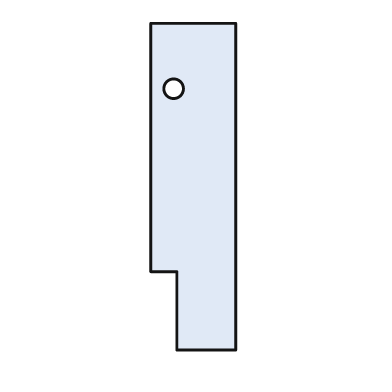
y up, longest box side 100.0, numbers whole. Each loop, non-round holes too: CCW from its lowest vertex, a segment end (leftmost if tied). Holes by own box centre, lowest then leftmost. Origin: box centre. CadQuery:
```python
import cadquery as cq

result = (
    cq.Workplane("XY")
    .moveTo(-5.0, -50.0)
    .lineTo(13.0, -50.0)
    .lineTo(13.0, 50.0)
    .lineTo(-13.0, 50.0)
    .lineTo(-13.0, -26.0)
    .lineTo(-5.0, -26.0)
    .close()
    .moveTo(-6.0, 30.0)
    .circle(3.0)
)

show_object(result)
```